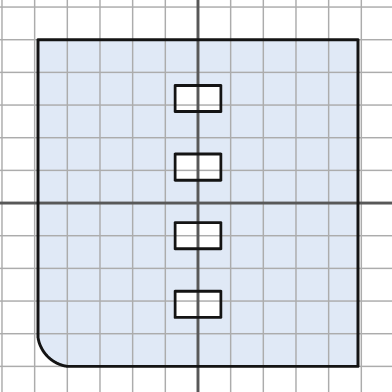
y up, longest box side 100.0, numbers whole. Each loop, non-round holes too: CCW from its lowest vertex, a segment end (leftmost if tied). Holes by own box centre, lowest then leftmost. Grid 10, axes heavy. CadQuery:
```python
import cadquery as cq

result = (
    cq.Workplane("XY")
    .moveTo(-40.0, -50.0)
    .lineTo(49.0, -50.0)
    .lineTo(49.0, 50.0)
    .lineTo(-49.0, 50.0)
    .lineTo(-49.0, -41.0)
    .threePointArc((-46.0, -47.0), (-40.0, -50.0))
    .close()
    .moveTo(-7.0, -35.0)
    .lineTo(7.0, -35.0)
    .lineTo(7.0, -27.0)
    .lineTo(-7.0, -27.0)
    .close()
    .moveTo(-7.0, -14.0)
    .lineTo(7.0, -14.0)
    .lineTo(7.0, -6.0)
    .lineTo(-7.0, -6.0)
    .close()
    .moveTo(-7.0, 7.0)
    .lineTo(7.0, 7.0)
    .lineTo(7.0, 15.0)
    .lineTo(-7.0, 15.0)
    .close()
    .moveTo(-7.0, 28.0)
    .lineTo(7.0, 28.0)
    .lineTo(7.0, 36.0)
    .lineTo(-7.0, 36.0)
    .close()
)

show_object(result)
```